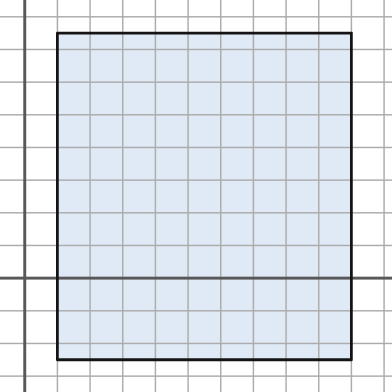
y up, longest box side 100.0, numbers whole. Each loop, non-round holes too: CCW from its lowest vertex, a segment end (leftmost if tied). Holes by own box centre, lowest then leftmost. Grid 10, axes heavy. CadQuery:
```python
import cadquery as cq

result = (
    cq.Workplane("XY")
    .moveTo(10.0, -25.0)
    .lineTo(100.0, -25.0)
    .lineTo(100.0, 75.0)
    .lineTo(10.0, 75.0)
    .close()
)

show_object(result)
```